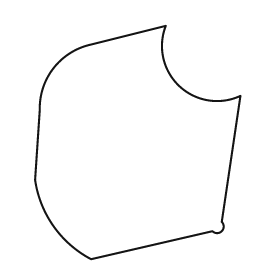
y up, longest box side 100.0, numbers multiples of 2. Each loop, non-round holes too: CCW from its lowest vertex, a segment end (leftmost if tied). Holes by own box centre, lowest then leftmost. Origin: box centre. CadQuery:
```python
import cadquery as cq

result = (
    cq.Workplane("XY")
    .moveTo(-20.0, -50.0)
    .lineTo(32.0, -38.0)
    .threePointArc((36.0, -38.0), (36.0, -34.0))
    .lineTo(44.0, 20.0)
    .threePointArc((18.0, 24.0), (12.0, 50.0))
    .lineTo(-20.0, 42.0)
    .threePointArc((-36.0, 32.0), (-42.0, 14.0))
    .lineTo(-44.0, -16.0)
    .threePointArc((-36.0, -36.0), (-20.0, -50.0))
    .close()
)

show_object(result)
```